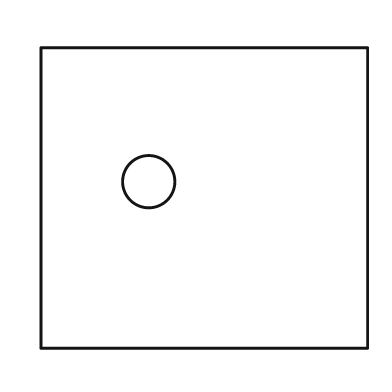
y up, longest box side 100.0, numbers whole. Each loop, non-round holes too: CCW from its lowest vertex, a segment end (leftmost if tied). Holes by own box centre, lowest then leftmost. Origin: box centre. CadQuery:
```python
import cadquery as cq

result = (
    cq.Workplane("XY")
    .moveTo(-50.0, -46.0)
    .lineTo(50.0, -46.0)
    .lineTo(50.0, 46.0)
    .lineTo(-50.0, 46.0)
    .close()
    .moveTo(-17.0, 5.0)
    .circle(8.0)
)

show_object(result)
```